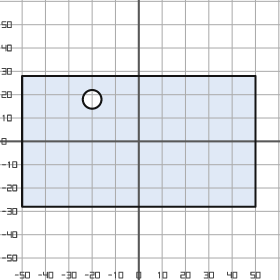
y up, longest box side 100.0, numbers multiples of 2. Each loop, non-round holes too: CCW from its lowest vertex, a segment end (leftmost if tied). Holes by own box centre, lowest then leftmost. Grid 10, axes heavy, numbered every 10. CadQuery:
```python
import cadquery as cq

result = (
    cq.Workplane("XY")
    .moveTo(-50.0, -28.0)
    .lineTo(50.0, -28.0)
    .lineTo(50.0, 28.0)
    .lineTo(-50.0, 28.0)
    .close()
    .moveTo(-20.0, 18.0)
    .circle(4.0)
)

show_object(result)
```